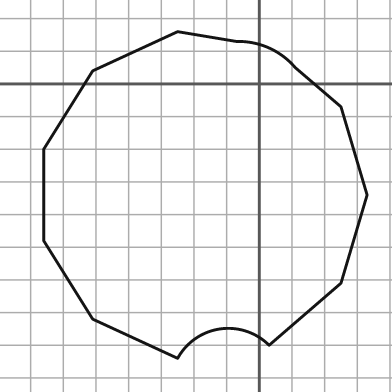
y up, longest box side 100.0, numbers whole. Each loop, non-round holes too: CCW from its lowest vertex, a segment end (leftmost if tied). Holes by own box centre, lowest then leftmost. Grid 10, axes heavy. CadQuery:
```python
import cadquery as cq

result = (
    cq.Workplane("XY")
    .moveTo(-25.0, -84.0)
    .threePointArc((-12.0, -75.0), (3.0, -80.0))
    .lineTo(25.0, -61.0)
    .lineTo(33.0, -34.0)
    .lineTo(25.0, -7.0)
    .lineTo(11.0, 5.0)
    .threePointArc((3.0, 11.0), (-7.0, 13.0))
    .lineTo(-25.0, 16.0)
    .lineTo(-51.0, 4.0)
    .lineTo(-66.0, -20.0)
    .lineTo(-66.0, -48.0)
    .lineTo(-51.0, -72.0)
    .close()
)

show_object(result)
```